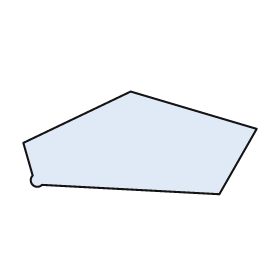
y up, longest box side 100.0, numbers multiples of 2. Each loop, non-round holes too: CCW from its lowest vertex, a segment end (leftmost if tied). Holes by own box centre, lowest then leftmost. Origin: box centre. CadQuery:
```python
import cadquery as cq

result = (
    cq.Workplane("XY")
    .moveTo(34.0, -22.0)
    .lineTo(50.0, 6.0)
    .lineTo(-4.0, 22.0)
    .lineTo(-50.0, 0.0)
    .lineTo(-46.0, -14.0)
    .threePointArc((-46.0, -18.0), (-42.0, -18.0))
    .close()
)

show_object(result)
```